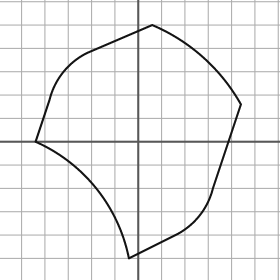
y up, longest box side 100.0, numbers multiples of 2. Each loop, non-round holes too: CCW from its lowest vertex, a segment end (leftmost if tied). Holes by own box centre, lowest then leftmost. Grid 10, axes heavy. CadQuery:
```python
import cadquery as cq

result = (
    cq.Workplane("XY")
    .moveTo(-4.0, -50.0)
    .lineTo(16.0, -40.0)
    .threePointArc((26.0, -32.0), (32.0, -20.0))
    .lineTo(44.0, 16.0)
    .threePointArc((28.0, 36.0), (6.0, 50.0))
    .lineTo(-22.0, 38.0)
    .threePointArc((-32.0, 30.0), (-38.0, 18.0))
    .lineTo(-44.0, 0.0)
    .threePointArc((-18.0, -20.0), (-4.0, -50.0))
    .close()
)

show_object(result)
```